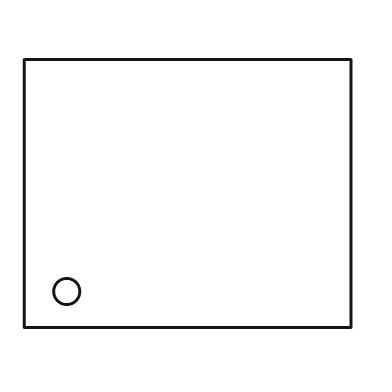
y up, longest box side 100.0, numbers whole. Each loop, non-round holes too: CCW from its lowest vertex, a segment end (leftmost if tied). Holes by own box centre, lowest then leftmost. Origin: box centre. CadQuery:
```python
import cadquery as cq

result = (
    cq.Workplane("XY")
    .moveTo(-50.0, -41.0)
    .lineTo(50.0, -41.0)
    .lineTo(50.0, 41.0)
    .lineTo(-50.0, 41.0)
    .close()
    .moveTo(-37.0, -30.0)
    .circle(4.0)
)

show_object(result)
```